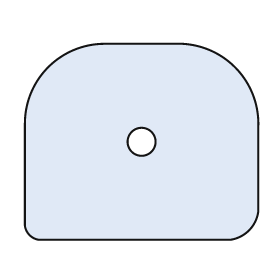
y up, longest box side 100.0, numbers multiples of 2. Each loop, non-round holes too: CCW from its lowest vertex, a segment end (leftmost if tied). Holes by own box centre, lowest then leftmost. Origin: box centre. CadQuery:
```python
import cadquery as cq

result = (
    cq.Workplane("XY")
    .moveTo(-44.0, -42.0)
    .lineTo(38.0, -42.0)
    .threePointArc((46.0, -38.0), (50.0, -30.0))
    .lineTo(50.0, 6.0)
    .threePointArc((40.0, 32.0), (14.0, 42.0))
    .lineTo(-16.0, 42.0)
    .threePointArc((-40.0, 32.0), (-50.0, 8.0))
    .lineTo(-50.0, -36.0)
    .threePointArc((-48.0, -40.0), (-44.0, -42.0))
    .close()
    .moveTo(0.0, 0.0)
    .circle(6.0)
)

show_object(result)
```